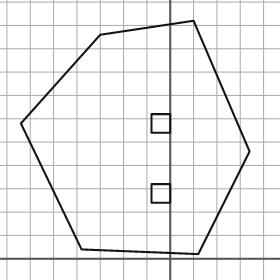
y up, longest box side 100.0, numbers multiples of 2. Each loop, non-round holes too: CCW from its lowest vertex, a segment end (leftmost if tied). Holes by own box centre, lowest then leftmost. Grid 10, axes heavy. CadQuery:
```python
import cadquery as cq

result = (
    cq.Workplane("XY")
    .moveTo(12.0, 2.0)
    .lineTo(34.0, 46.0)
    .lineTo(10.0, 102.0)
    .lineTo(-30.0, 96.0)
    .lineTo(-64.0, 58.0)
    .lineTo(-38.0, 4.0)
    .close()
    .moveTo(-8.0, 24.0)
    .lineTo(0.0, 24.0)
    .lineTo(0.0, 32.0)
    .lineTo(-8.0, 32.0)
    .close()
    .moveTo(-8.0, 54.0)
    .lineTo(0.0, 54.0)
    .lineTo(0.0, 62.0)
    .lineTo(-8.0, 62.0)
    .close()
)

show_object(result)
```